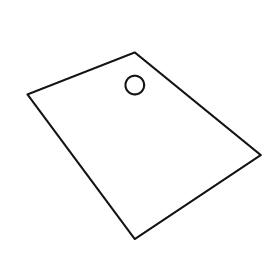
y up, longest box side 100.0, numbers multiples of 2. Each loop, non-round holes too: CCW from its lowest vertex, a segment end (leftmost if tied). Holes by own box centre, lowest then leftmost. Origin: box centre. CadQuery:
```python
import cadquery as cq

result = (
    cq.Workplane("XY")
    .moveTo(-4.0, -40.0)
    .lineTo(50.0, -4.0)
    .lineTo(-4.0, 40.0)
    .lineTo(-50.0, 22.0)
    .close()
    .moveTo(-4.0, 26.0)
    .circle(4.0)
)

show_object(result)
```